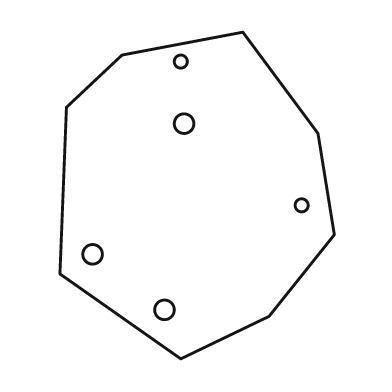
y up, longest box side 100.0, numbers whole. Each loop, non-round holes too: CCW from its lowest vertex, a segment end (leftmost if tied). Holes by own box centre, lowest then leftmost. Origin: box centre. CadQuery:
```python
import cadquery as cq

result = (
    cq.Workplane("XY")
    .moveTo(-5.0, -50.0)
    .lineTo(22.0, -37.0)
    .lineTo(42.0, -12.0)
    .lineTo(37.0, 19.0)
    .lineTo(14.0, 50.0)
    .lineTo(-23.0, 43.0)
    .lineTo(-40.0, 27.0)
    .lineTo(-42.0, -24.0)
    .close()
    .moveTo(-10.0, -35.0)
    .circle(3.0)
    .moveTo(-32.0, -18.0)
    .circle(3.0)
    .moveTo(32.0, -3.0)
    .circle(2.0)
    .moveTo(-4.0, 22.0)
    .circle(3.0)
    .moveTo(-5.0, 41.0)
    .circle(2.0)
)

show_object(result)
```